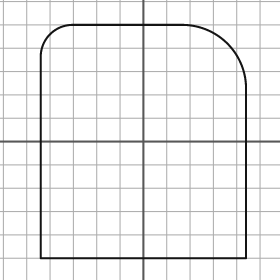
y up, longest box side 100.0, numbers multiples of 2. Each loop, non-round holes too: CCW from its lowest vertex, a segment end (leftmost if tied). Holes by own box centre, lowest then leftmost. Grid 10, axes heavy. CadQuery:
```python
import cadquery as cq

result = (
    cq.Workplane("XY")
    .moveTo(-44.0, -50.0)
    .lineTo(44.0, -50.0)
    .lineTo(44.0, 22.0)
    .threePointArc((36.0, 42.0), (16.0, 50.0))
    .lineTo(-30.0, 50.0)
    .threePointArc((-40.0, 46.0), (-44.0, 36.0))
    .close()
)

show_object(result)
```